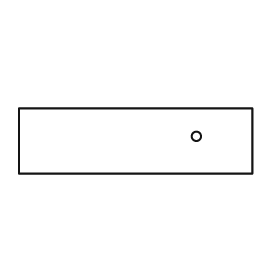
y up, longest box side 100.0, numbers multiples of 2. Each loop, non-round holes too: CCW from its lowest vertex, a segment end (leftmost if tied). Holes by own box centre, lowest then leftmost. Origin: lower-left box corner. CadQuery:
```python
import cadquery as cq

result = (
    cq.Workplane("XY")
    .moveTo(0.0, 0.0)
    .lineTo(100.0, 0.0)
    .lineTo(100.0, 28.0)
    .lineTo(0.0, 28.0)
    .close()
    .moveTo(76.0, 16.0)
    .circle(2.0)
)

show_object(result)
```